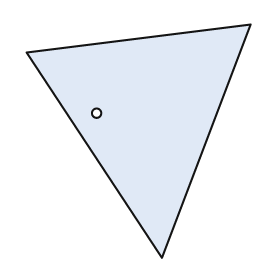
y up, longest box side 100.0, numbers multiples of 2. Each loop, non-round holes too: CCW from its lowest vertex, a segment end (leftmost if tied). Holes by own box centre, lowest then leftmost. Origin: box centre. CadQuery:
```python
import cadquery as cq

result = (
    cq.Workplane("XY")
    .moveTo(10.0, -50.0)
    .lineTo(48.0, 50.0)
    .lineTo(-48.0, 38.0)
    .close()
    .moveTo(-18.0, 12.0)
    .circle(2.0)
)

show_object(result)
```